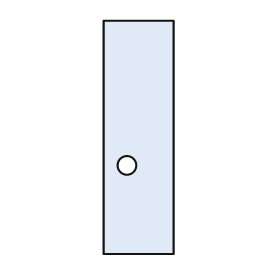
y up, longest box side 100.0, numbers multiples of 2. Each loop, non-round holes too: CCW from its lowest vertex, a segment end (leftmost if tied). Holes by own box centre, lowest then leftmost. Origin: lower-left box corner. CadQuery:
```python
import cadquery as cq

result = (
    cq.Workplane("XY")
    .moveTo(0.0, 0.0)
    .lineTo(30.0, 0.0)
    .lineTo(30.0, 100.0)
    .lineTo(0.0, 100.0)
    .close()
    .moveTo(10.0, 38.0)
    .circle(4.0)
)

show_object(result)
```